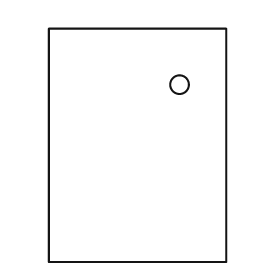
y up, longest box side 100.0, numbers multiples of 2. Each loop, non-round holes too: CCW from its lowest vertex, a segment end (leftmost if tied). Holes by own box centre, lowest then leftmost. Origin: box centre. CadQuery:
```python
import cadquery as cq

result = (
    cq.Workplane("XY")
    .moveTo(-38.0, -50.0)
    .lineTo(38.0, -50.0)
    .lineTo(38.0, 50.0)
    .lineTo(-38.0, 50.0)
    .close()
    .moveTo(18.0, 26.0)
    .circle(4.0)
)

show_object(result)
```